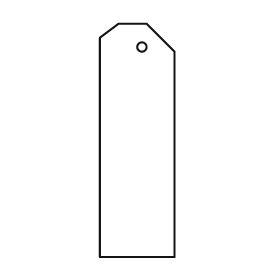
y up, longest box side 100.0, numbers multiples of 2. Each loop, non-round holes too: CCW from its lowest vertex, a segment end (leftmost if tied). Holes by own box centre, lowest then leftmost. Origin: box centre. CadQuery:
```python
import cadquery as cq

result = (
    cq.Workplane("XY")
    .moveTo(-16.0, -50.0)
    .lineTo(16.0, -50.0)
    .lineTo(16.0, 38.0)
    .lineTo(4.0, 50.0)
    .lineTo(-8.0, 50.0)
    .lineTo(-16.0, 44.0)
    .close()
    .moveTo(2.0, 40.0)
    .circle(2.0)
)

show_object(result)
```